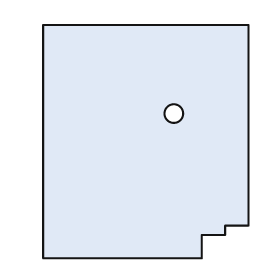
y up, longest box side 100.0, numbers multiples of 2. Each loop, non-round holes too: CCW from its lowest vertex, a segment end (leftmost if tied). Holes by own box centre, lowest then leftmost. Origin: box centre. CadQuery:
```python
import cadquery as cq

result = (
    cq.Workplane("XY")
    .moveTo(-44.0, -50.0)
    .lineTo(24.0, -50.0)
    .lineTo(24.0, -40.0)
    .lineTo(34.0, -40.0)
    .lineTo(34.0, -36.0)
    .lineTo(44.0, -36.0)
    .lineTo(44.0, 50.0)
    .lineTo(-44.0, 50.0)
    .close()
    .moveTo(12.0, 12.0)
    .circle(4.0)
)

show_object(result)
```